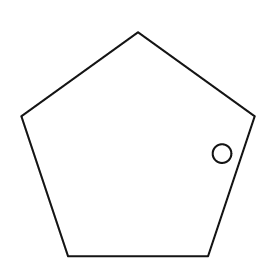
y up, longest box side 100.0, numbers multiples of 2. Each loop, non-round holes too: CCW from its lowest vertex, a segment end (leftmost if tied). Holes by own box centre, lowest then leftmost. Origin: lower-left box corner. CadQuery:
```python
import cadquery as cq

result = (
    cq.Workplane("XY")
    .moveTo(20.0, 0.0)
    .lineTo(80.0, 0.0)
    .lineTo(100.0, 60.0)
    .lineTo(50.0, 96.0)
    .lineTo(0.0, 60.0)
    .close()
    .moveTo(86.0, 44.0)
    .circle(4.0)
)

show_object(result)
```